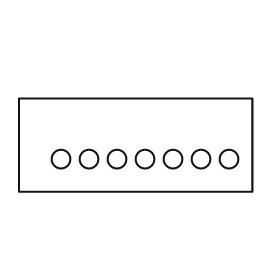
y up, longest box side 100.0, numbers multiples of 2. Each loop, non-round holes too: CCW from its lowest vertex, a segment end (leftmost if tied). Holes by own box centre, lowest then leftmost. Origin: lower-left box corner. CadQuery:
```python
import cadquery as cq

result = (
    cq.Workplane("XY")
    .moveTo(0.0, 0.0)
    .lineTo(100.0, 0.0)
    .lineTo(100.0, 40.0)
    .lineTo(0.0, 40.0)
    .close()
    .moveTo(18.0, 14.0)
    .circle(4.0)
    .moveTo(30.0, 14.0)
    .circle(4.0)
    .moveTo(42.0, 14.0)
    .circle(4.0)
    .moveTo(54.0, 14.0)
    .circle(4.0)
    .moveTo(66.0, 14.0)
    .circle(4.0)
    .moveTo(78.0, 14.0)
    .circle(4.0)
    .moveTo(90.0, 14.0)
    .circle(4.0)
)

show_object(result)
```